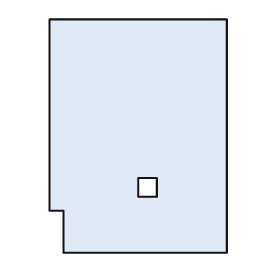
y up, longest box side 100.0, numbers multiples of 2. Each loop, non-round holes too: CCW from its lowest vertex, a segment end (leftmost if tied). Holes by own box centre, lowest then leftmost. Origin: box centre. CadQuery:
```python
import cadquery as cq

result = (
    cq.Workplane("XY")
    .moveTo(-32.0, -50.0)
    .lineTo(38.0, -50.0)
    .lineTo(38.0, 50.0)
    .lineTo(-38.0, 50.0)
    .lineTo(-38.0, -32.0)
    .lineTo(-32.0, -32.0)
    .close()
    .moveTo(0.0, -26.0)
    .lineTo(8.0, -26.0)
    .lineTo(8.0, -18.0)
    .lineTo(0.0, -18.0)
    .close()
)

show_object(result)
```